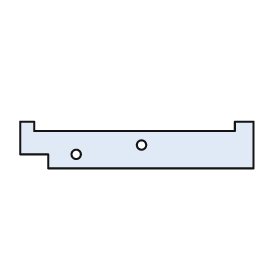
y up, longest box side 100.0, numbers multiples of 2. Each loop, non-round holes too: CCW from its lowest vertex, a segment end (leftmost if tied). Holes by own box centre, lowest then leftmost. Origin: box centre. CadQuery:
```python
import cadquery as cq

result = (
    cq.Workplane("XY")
    .moveTo(-38.0, -10.0)
    .lineTo(50.0, -10.0)
    .lineTo(50.0, 10.0)
    .lineTo(42.0, 10.0)
    .lineTo(42.0, 6.0)
    .lineTo(-44.0, 6.0)
    .lineTo(-44.0, 10.0)
    .lineTo(-50.0, 10.0)
    .lineTo(-50.0, -4.0)
    .lineTo(-38.0, -4.0)
    .close()
    .moveTo(-26.0, -4.0)
    .circle(2.0)
    .moveTo(2.0, 0.0)
    .circle(2.0)
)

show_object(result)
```